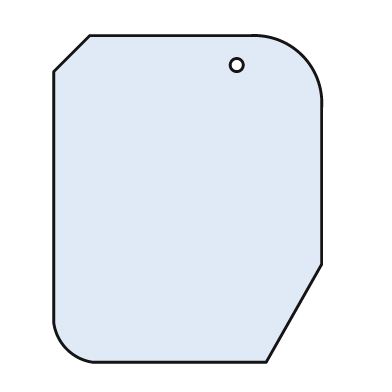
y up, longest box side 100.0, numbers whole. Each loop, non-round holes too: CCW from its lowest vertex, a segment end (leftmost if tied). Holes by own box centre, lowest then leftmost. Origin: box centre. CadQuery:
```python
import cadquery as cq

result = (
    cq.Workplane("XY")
    .moveTo(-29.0, -50.0)
    .lineTo(24.0, -50.0)
    .lineTo(41.0, -20.0)
    .lineTo(41.0, 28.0)
    .threePointArc((35.0, 44.0), (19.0, 50.0))
    .lineTo(-30.0, 50.0)
    .lineTo(-41.0, 39.0)
    .lineTo(-41.0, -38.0)
    .threePointArc((-37.0, -46.0), (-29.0, -50.0))
    .close()
    .moveTo(15.0, 41.0)
    .circle(2.0)
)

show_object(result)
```